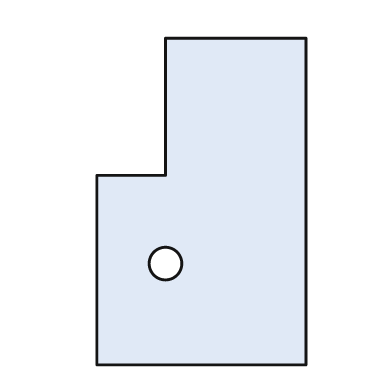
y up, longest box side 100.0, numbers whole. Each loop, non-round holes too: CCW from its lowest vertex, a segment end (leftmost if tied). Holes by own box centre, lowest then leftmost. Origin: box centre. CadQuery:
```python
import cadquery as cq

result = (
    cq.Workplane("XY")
    .moveTo(-32.0, -50.0)
    .lineTo(32.0, -50.0)
    .lineTo(32.0, 50.0)
    .lineTo(-11.0, 50.0)
    .lineTo(-11.0, 8.0)
    .lineTo(-32.0, 8.0)
    .close()
    .moveTo(-11.0, -19.0)
    .circle(5.0)
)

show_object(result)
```